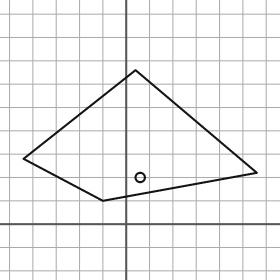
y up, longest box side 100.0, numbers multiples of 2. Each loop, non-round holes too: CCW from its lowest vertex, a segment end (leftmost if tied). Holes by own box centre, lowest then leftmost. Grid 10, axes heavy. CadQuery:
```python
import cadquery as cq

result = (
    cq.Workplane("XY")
    .moveTo(-10.0, 10.0)
    .lineTo(56.0, 22.0)
    .lineTo(4.0, 66.0)
    .lineTo(-44.0, 28.0)
    .close()
    .moveTo(6.0, 20.0)
    .circle(2.0)
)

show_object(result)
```